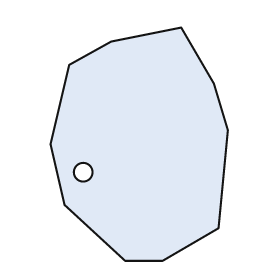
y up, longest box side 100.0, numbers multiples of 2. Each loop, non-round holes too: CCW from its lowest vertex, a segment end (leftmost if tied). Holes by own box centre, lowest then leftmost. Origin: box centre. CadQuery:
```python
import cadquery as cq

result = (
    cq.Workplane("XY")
    .moveTo(-6.0, -50.0)
    .lineTo(10.0, -50.0)
    .lineTo(34.0, -36.0)
    .lineTo(38.0, 6.0)
    .lineTo(32.0, 26.0)
    .lineTo(18.0, 50.0)
    .lineTo(-12.0, 44.0)
    .lineTo(-30.0, 34.0)
    .lineTo(-38.0, 0.0)
    .lineTo(-32.0, -26.0)
    .close()
    .moveTo(-24.0, -12.0)
    .circle(4.0)
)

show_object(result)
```